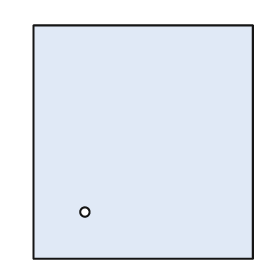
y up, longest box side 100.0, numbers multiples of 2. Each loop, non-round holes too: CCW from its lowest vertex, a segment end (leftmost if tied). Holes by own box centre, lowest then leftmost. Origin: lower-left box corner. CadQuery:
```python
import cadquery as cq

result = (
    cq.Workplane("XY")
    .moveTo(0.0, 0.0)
    .lineTo(94.0, 0.0)
    .lineTo(94.0, 100.0)
    .lineTo(0.0, 100.0)
    .close()
    .moveTo(22.0, 20.0)
    .circle(2.0)
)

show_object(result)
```